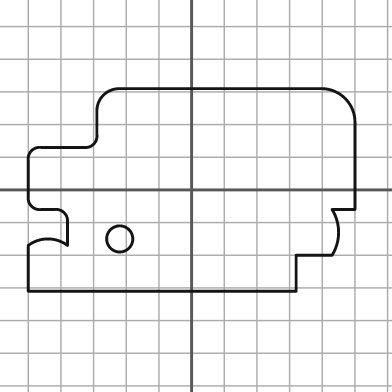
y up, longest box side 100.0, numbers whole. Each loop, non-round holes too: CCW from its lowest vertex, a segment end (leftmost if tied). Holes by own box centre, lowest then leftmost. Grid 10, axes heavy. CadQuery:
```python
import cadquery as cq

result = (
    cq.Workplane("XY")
    .moveTo(-50.0, -31.0)
    .lineTo(32.0, -31.0)
    .lineTo(32.0, -20.0)
    .lineTo(43.0, -20.0)
    .threePointArc((45.0, -13.0), (43.0, -6.0))
    .lineTo(50.0, -6.0)
    .lineTo(50.0, 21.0)
    .threePointArc((47.0, 28.0), (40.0, 31.0))
    .lineTo(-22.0, 31.0)
    .threePointArc((-27.0, 29.0), (-29.0, 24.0))
    .lineTo(-29.0, 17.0)
    .threePointArc((-30.0, 14.0), (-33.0, 13.0))
    .lineTo(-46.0, 13.0)
    .threePointArc((-49.0, 12.0), (-50.0, 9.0))
    .lineTo(-50.0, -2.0)
    .threePointArc((-49.0, -5.0), (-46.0, -6.0))
    .lineTo(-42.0, -6.0)
    .threePointArc((-39.0, -7.0), (-38.0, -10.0))
    .lineTo(-38.0, -17.0)
    .threePointArc((-44.0, -15.0), (-50.0, -17.0))
    .close()
    .moveTo(-22.0, -15.0)
    .circle(4.0)
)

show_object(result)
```